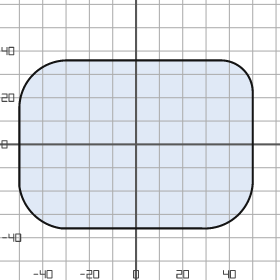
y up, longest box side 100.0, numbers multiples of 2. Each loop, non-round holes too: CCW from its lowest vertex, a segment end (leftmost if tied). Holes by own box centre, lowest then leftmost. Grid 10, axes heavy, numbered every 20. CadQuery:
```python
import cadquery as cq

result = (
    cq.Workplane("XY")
    .moveTo(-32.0, -36.0)
    .lineTo(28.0, -36.0)
    .threePointArc((44.0, -30.0), (50.0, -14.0))
    .lineTo(50.0, 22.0)
    .threePointArc((46.0, 32.0), (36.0, 36.0))
    .lineTo(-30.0, 36.0)
    .threePointArc((-44.0, 30.0), (-50.0, 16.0))
    .lineTo(-50.0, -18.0)
    .threePointArc((-44.0, -30.0), (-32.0, -36.0))
    .close()
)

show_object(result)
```